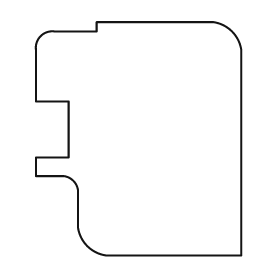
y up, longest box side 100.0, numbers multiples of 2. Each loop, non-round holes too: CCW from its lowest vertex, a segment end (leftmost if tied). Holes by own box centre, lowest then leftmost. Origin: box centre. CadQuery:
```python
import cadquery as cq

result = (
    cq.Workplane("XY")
    .moveTo(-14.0, -50.0)
    .lineTo(44.0, -50.0)
    .lineTo(44.0, 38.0)
    .threePointArc((40.0, 46.0), (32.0, 50.0))
    .lineTo(-18.0, 50.0)
    .lineTo(-18.0, 46.0)
    .lineTo(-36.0, 46.0)
    .threePointArc((-42.0, 44.0), (-44.0, 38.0))
    .lineTo(-44.0, 16.0)
    .lineTo(-30.0, 16.0)
    .lineTo(-30.0, -8.0)
    .lineTo(-44.0, -8.0)
    .lineTo(-44.0, -16.0)
    .lineTo(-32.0, -16.0)
    .threePointArc((-28.0, -18.0), (-26.0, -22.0))
    .lineTo(-26.0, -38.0)
    .threePointArc((-22.0, -46.0), (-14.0, -50.0))
    .close()
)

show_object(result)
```